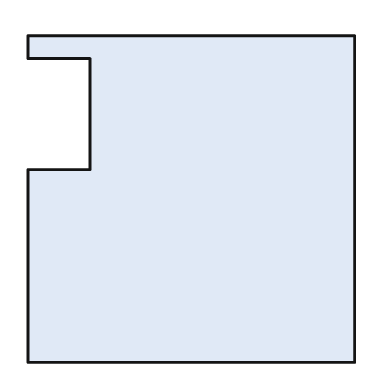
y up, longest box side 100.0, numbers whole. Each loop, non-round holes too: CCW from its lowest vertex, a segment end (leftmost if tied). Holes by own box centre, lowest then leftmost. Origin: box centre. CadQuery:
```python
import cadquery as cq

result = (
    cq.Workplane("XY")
    .moveTo(-50.0, -50.0)
    .lineTo(50.0, -50.0)
    .lineTo(50.0, 50.0)
    .lineTo(-50.0, 50.0)
    .lineTo(-50.0, 43.0)
    .lineTo(-31.0, 43.0)
    .lineTo(-31.0, 9.0)
    .lineTo(-50.0, 9.0)
    .close()
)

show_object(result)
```